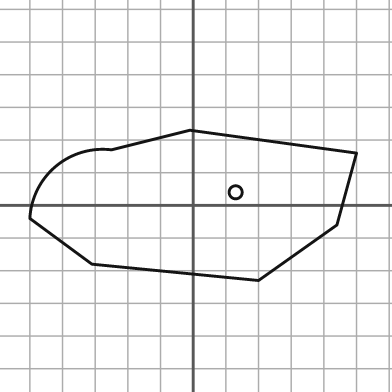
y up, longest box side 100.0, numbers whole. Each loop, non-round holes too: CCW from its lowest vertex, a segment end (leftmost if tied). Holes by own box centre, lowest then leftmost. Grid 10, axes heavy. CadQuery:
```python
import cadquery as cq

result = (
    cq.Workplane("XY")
    .moveTo(20.0, -23.0)
    .lineTo(44.0, -6.0)
    .lineTo(50.0, 16.0)
    .lineTo(-1.0, 23.0)
    .lineTo(-25.0, 17.0)
    .threePointArc((-42.0, 12.0), (-50.0, -4.0))
    .lineTo(-31.0, -18.0)
    .close()
    .moveTo(13.0, 4.0)
    .circle(2.0)
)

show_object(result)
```